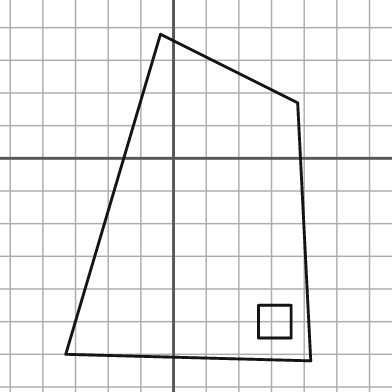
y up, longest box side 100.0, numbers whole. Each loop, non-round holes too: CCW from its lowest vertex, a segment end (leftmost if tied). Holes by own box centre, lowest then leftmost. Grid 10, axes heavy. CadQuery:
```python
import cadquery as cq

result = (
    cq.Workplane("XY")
    .moveTo(42.0, -62.0)
    .lineTo(38.0, 17.0)
    .lineTo(-4.0, 38.0)
    .lineTo(-33.0, -60.0)
    .close()
    .moveTo(26.0, -55.0)
    .lineTo(36.0, -55.0)
    .lineTo(36.0, -45.0)
    .lineTo(26.0, -45.0)
    .close()
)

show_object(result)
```